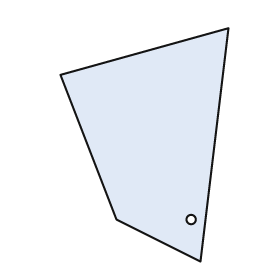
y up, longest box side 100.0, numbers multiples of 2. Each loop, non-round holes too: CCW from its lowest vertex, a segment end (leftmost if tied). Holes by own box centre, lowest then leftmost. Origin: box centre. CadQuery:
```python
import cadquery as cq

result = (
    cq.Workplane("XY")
    .moveTo(24.0, -50.0)
    .lineTo(36.0, 50.0)
    .lineTo(-36.0, 30.0)
    .lineTo(-12.0, -32.0)
    .close()
    .moveTo(20.0, -32.0)
    .circle(2.0)
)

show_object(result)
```